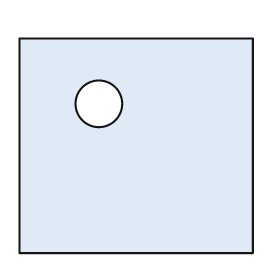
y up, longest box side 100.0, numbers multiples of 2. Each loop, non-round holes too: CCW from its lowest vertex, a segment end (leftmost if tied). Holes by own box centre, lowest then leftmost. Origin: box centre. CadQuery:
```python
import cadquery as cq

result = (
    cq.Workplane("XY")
    .moveTo(-50.0, -46.0)
    .lineTo(50.0, -46.0)
    .lineTo(50.0, 46.0)
    .lineTo(-50.0, 46.0)
    .close()
    .moveTo(-16.0, 18.0)
    .circle(10.0)
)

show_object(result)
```